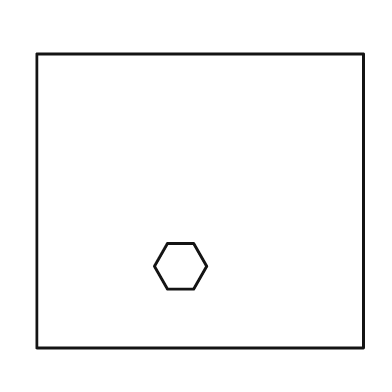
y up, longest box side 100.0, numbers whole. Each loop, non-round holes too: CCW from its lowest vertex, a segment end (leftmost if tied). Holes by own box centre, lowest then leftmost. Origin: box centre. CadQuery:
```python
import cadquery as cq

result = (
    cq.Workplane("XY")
    .moveTo(-50.0, -45.0)
    .lineTo(50.0, -45.0)
    .lineTo(50.0, 45.0)
    .lineTo(-50.0, 45.0)
    .close()
    .moveTo(-10.0, -27.0)
    .lineTo(-2.0, -27.0)
    .lineTo(2.0, -20.0)
    .lineTo(-2.0, -13.0)
    .lineTo(-10.0, -13.0)
    .lineTo(-14.0, -20.0)
    .close()
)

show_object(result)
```